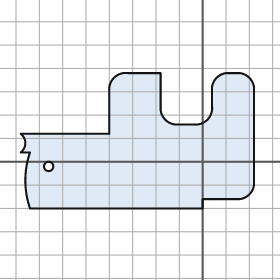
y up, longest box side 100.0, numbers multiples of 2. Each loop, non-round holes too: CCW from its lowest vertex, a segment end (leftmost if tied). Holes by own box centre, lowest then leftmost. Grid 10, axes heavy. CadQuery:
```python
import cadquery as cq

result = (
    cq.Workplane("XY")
    .moveTo(-74.0, -20.0)
    .lineTo(0.0, -20.0)
    .lineTo(0.0, -16.0)
    .lineTo(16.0, -16.0)
    .threePointArc((20.0, -14.0), (22.0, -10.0))
    .lineTo(22.0, 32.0)
    .threePointArc((20.0, 36.0), (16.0, 38.0))
    .lineTo(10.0, 38.0)
    .threePointArc((6.0, 36.0), (4.0, 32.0))
    .lineTo(4.0, 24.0)
    .threePointArc((2.0, 18.0), (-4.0, 16.0))
    .lineTo(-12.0, 16.0)
    .threePointArc((-16.0, 18.0), (-18.0, 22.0))
    .lineTo(-18.0, 38.0)
    .lineTo(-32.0, 38.0)
    .threePointArc((-38.0, 36.0), (-40.0, 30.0))
    .lineTo(-40.0, 12.0)
    .lineTo(-78.0, 12.0)
    .threePointArc((-76.0, 8.0), (-78.0, 4.0))
    .lineTo(-74.0, 4.0)
    .threePointArc((-76.0, -8.0), (-74.0, -20.0))
    .close()
    .moveTo(-66.0, -2.0)
    .circle(2.0)
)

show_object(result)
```